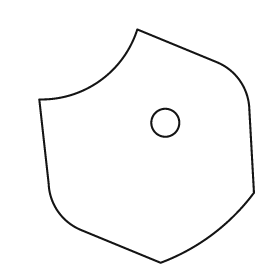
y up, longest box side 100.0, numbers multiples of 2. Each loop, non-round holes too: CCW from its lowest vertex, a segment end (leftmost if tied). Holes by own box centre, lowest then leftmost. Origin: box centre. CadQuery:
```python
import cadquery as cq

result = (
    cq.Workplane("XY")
    .moveTo(6.0, -50.0)
    .threePointArc((28.0, -38.0), (46.0, -20.0))
    .lineTo(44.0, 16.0)
    .threePointArc((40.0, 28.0), (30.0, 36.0))
    .lineTo(-4.0, 50.0)
    .threePointArc((-20.0, 28.0), (-46.0, 20.0))
    .lineTo(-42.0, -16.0)
    .threePointArc((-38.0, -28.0), (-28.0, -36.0))
    .close()
    .moveTo(8.0, 10.0)
    .circle(6.0)
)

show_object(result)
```